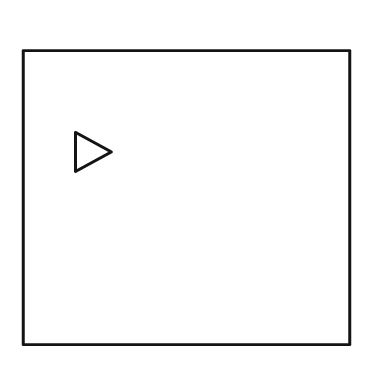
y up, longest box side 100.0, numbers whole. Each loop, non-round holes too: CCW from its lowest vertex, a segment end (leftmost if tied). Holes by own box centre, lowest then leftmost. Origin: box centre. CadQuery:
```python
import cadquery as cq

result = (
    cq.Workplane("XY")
    .moveTo(-50.0, -45.0)
    .lineTo(50.0, -45.0)
    .lineTo(50.0, 45.0)
    .lineTo(-50.0, 45.0)
    .close()
    .moveTo(-34.0, 8.0)
    .lineTo(-23.0, 14.0)
    .lineTo(-34.0, 20.0)
    .close()
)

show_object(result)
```